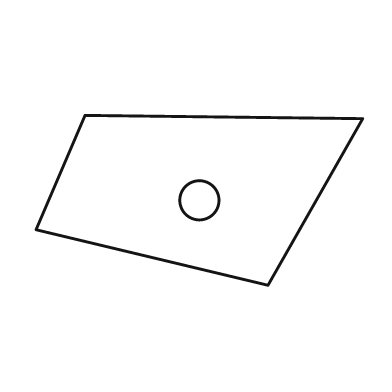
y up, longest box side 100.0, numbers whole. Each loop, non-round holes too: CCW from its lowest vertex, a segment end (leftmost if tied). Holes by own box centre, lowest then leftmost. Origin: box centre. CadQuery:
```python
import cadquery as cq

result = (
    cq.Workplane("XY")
    .moveTo(21.0, -26.0)
    .lineTo(50.0, 25.0)
    .lineTo(-35.0, 26.0)
    .lineTo(-50.0, -9.0)
    .close()
    .moveTo(0.0, 0.0)
    .circle(6.0)
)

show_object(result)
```